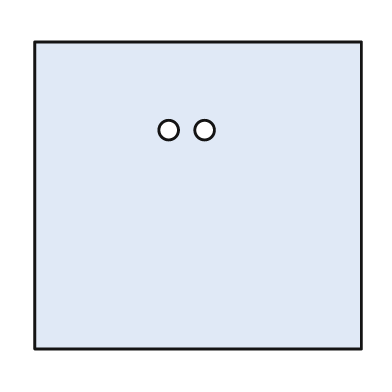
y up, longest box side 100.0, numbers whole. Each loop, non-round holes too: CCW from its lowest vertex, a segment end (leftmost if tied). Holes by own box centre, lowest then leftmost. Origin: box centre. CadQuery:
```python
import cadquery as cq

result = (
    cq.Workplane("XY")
    .moveTo(-50.0, -47.0)
    .lineTo(50.0, -47.0)
    .lineTo(50.0, 47.0)
    .lineTo(-50.0, 47.0)
    .close()
    .moveTo(-9.0, 20.0)
    .circle(3.0)
    .moveTo(2.0, 20.0)
    .circle(3.0)
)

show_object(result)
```